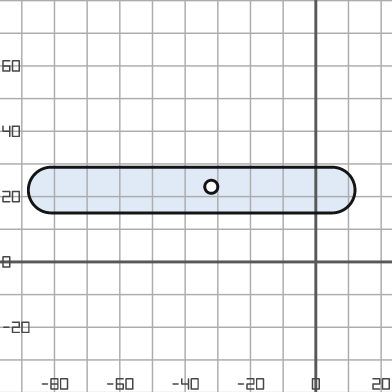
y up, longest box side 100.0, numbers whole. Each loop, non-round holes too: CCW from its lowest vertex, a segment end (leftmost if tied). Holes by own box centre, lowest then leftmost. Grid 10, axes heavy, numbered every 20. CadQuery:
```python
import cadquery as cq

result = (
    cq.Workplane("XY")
    .moveTo(-81.0, 15.0)
    .lineTo(5.0, 15.0)
    .threePointArc((12.0, 22.0), (5.0, 29.0))
    .lineTo(-81.0, 29.0)
    .threePointArc((-88.0, 22.0), (-81.0, 15.0))
    .close()
    .moveTo(-32.0, 23.0)
    .circle(2.0)
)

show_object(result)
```